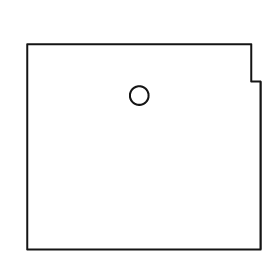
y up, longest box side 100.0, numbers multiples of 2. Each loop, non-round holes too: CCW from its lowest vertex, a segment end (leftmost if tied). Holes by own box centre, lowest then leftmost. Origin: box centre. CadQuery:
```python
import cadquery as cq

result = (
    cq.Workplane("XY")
    .moveTo(-50.0, -44.0)
    .lineTo(50.0, -44.0)
    .lineTo(50.0, 28.0)
    .lineTo(46.0, 28.0)
    .lineTo(46.0, 44.0)
    .lineTo(-50.0, 44.0)
    .close()
    .moveTo(-2.0, 22.0)
    .circle(4.0)
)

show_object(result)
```